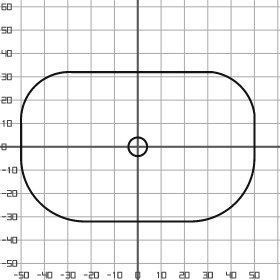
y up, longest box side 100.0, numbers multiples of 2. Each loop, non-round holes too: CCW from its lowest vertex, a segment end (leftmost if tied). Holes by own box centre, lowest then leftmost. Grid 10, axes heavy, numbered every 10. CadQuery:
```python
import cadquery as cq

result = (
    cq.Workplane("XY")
    .moveTo(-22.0, -32.0)
    .lineTo(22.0, -32.0)
    .threePointArc((42.0, -24.0), (50.0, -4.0))
    .lineTo(50.0, 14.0)
    .threePointArc((44.0, 26.0), (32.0, 32.0))
    .lineTo(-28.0, 32.0)
    .threePointArc((-44.0, 26.0), (-50.0, 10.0))
    .lineTo(-50.0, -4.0)
    .threePointArc((-42.0, -24.0), (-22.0, -32.0))
    .close()
    .moveTo(0.0, 0.0)
    .circle(4.0)
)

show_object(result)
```